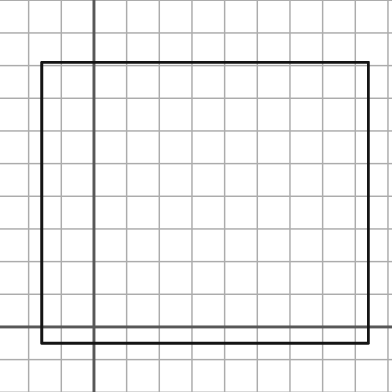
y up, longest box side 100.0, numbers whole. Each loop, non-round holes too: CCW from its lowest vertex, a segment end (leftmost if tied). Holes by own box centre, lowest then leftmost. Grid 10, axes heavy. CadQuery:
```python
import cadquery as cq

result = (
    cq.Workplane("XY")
    .moveTo(-16.0, -5.0)
    .lineTo(84.0, -5.0)
    .lineTo(84.0, 81.0)
    .lineTo(-16.0, 81.0)
    .close()
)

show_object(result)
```